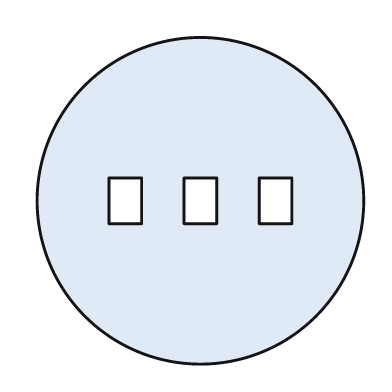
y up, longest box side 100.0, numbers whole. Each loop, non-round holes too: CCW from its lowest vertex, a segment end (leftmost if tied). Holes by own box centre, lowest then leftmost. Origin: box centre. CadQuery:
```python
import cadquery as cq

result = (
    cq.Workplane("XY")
    .moveTo(0.0, 0.0)
    .circle(50.0)
    .moveTo(-28.0, -7.0)
    .lineTo(-18.0, -7.0)
    .lineTo(-18.0, 7.0)
    .lineTo(-28.0, 7.0)
    .close()
    .moveTo(-5.0, -7.0)
    .lineTo(5.0, -7.0)
    .lineTo(5.0, 7.0)
    .lineTo(-5.0, 7.0)
    .close()
    .moveTo(18.0, -7.0)
    .lineTo(28.0, -7.0)
    .lineTo(28.0, 7.0)
    .lineTo(18.0, 7.0)
    .close()
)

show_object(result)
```